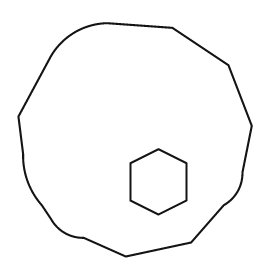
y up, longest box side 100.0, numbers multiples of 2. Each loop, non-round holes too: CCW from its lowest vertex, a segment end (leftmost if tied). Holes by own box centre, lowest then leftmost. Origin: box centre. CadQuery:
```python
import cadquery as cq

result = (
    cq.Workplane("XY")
    .moveTo(-4.0, -50.0)
    .lineTo(24.0, -44.0)
    .lineTo(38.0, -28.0)
    .threePointArc((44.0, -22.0), (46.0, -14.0))
    .lineTo(50.0, 6.0)
    .lineTo(40.0, 32.0)
    .lineTo(16.0, 48.0)
    .lineTo(-12.0, 50.0)
    .threePointArc((-26.0, 46.0), (-36.0, 36.0))
    .lineTo(-50.0, 10.0)
    .lineTo(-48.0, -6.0)
    .threePointArc((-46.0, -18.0), (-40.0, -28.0))
    .lineTo(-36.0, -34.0)
    .threePointArc((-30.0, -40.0), (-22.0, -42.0))
    .close()
    .moveTo(10.0, -32.0)
    .lineTo(22.0, -26.0)
    .lineTo(22.0, -10.0)
    .lineTo(10.0, -4.0)
    .lineTo(-2.0, -10.0)
    .lineTo(-2.0, -26.0)
    .close()
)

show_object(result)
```